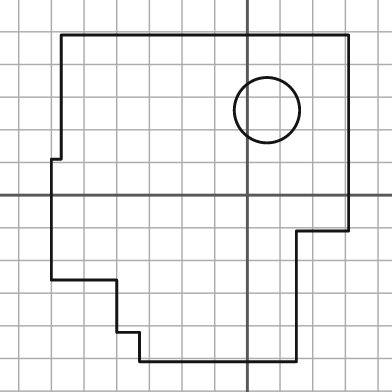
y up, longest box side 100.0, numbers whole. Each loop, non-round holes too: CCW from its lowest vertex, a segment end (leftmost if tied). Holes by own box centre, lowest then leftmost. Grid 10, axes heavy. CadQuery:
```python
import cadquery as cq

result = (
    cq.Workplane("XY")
    .moveTo(-33.0, -51.0)
    .lineTo(15.0, -51.0)
    .lineTo(15.0, -11.0)
    .lineTo(31.0, -11.0)
    .lineTo(31.0, 49.0)
    .lineTo(-57.0, 49.0)
    .lineTo(-57.0, 11.0)
    .lineTo(-60.0, 11.0)
    .lineTo(-60.0, -26.0)
    .lineTo(-40.0, -26.0)
    .lineTo(-40.0, -42.0)
    .lineTo(-33.0, -42.0)
    .close()
    .moveTo(6.0, 26.0)
    .circle(10.0)
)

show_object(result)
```